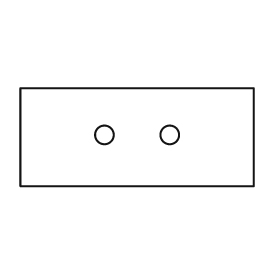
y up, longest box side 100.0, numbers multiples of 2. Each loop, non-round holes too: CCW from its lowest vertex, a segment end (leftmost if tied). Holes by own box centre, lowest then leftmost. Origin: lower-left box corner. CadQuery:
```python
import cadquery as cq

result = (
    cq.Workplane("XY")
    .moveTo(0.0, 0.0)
    .lineTo(100.0, 0.0)
    .lineTo(100.0, 42.0)
    .lineTo(0.0, 42.0)
    .close()
    .moveTo(36.0, 22.0)
    .circle(4.0)
    .moveTo(64.0, 22.0)
    .circle(4.0)
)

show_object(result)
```